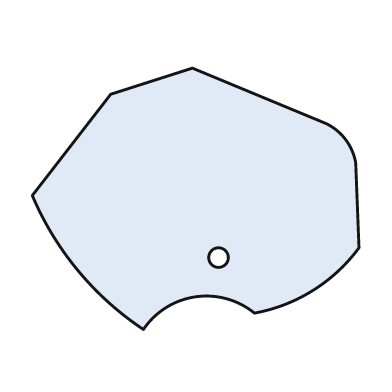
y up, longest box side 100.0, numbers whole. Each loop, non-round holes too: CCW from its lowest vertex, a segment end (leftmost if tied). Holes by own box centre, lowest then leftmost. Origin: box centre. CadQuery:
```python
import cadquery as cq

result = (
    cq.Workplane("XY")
    .moveTo(-16.0, -40.0)
    .threePointArc((0.0, -30.0), (18.0, -35.0))
    .threePointArc((36.0, -28.0), (50.0, -15.0))
    .lineTo(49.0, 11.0)
    .threePointArc((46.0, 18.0), (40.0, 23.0))
    .lineTo(-1.0, 40.0)
    .lineTo(-26.0, 32.0)
    .lineTo(-50.0, 1.0)
    .threePointArc((-36.0, -22.0), (-16.0, -40.0))
    .close()
    .moveTo(7.0, -18.0)
    .circle(3.0)
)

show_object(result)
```